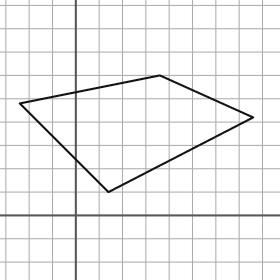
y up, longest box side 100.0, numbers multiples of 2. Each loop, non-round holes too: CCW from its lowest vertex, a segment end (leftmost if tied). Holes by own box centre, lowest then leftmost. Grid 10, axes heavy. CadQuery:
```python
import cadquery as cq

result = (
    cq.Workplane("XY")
    .moveTo(14.0, 10.0)
    .lineTo(76.0, 42.0)
    .lineTo(36.0, 60.0)
    .lineTo(-24.0, 48.0)
    .close()
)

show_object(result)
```